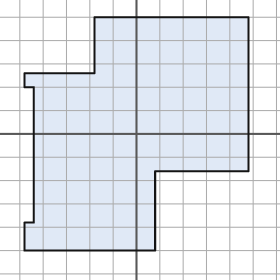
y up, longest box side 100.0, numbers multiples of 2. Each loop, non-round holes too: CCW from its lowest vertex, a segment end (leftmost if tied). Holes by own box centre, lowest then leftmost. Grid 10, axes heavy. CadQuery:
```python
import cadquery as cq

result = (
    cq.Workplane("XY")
    .moveTo(-48.0, -50.0)
    .lineTo(8.0, -50.0)
    .lineTo(8.0, -16.0)
    .lineTo(48.0, -16.0)
    .lineTo(48.0, 50.0)
    .lineTo(-18.0, 50.0)
    .lineTo(-18.0, 26.0)
    .lineTo(-48.0, 26.0)
    .lineTo(-48.0, 20.0)
    .lineTo(-44.0, 20.0)
    .lineTo(-44.0, -38.0)
    .lineTo(-48.0, -38.0)
    .close()
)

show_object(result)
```